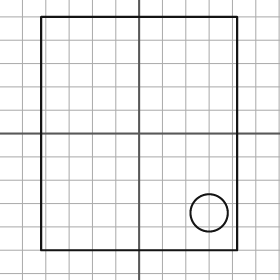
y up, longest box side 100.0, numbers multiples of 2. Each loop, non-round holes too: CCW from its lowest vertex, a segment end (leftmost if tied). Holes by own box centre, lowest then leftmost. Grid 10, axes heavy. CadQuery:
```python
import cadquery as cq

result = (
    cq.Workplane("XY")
    .moveTo(-42.0, -50.0)
    .lineTo(42.0, -50.0)
    .lineTo(42.0, 50.0)
    .lineTo(-42.0, 50.0)
    .close()
    .moveTo(30.0, -34.0)
    .circle(8.0)
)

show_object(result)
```